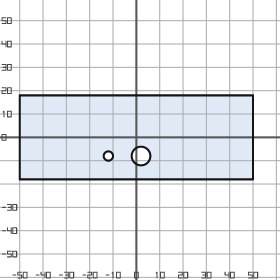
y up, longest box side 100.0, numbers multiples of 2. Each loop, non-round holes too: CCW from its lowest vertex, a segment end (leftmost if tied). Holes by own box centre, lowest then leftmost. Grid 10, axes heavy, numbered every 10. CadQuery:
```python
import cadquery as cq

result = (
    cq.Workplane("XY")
    .moveTo(-50.0, -18.0)
    .lineTo(50.0, -18.0)
    .lineTo(50.0, 18.0)
    .lineTo(-50.0, 18.0)
    .close()
    .moveTo(-12.0, -8.0)
    .circle(2.0)
    .moveTo(2.0, -8.0)
    .circle(4.0)
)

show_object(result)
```